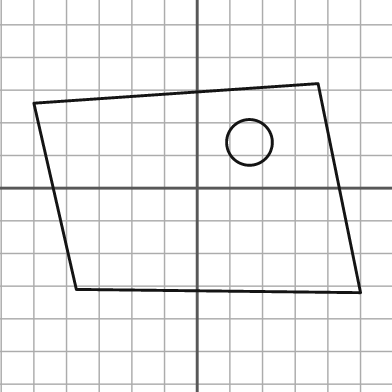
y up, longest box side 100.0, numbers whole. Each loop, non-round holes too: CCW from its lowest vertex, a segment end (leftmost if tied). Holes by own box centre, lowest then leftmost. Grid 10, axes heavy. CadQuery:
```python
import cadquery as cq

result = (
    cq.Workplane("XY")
    .moveTo(50.0, -32.0)
    .lineTo(37.0, 32.0)
    .lineTo(-50.0, 26.0)
    .lineTo(-37.0, -31.0)
    .close()
    .moveTo(16.0, 14.0)
    .circle(7.0)
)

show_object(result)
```